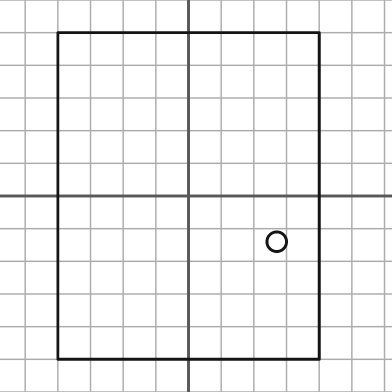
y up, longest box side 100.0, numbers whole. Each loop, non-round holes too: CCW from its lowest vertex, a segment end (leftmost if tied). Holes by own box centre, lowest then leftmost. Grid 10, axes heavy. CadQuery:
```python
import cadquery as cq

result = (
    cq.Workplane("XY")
    .moveTo(-40.0, -50.0)
    .lineTo(40.0, -50.0)
    .lineTo(40.0, 50.0)
    .lineTo(-40.0, 50.0)
    .close()
    .moveTo(27.0, -14.0)
    .circle(3.0)
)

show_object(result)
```